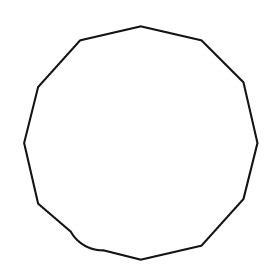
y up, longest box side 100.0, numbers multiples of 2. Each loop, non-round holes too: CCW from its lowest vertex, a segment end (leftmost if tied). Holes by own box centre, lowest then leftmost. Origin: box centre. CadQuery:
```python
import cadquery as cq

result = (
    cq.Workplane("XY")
    .moveTo(0.0, -50.0)
    .lineTo(26.0, -44.0)
    .lineTo(44.0, -24.0)
    .lineTo(50.0, 0.0)
    .lineTo(44.0, 26.0)
    .lineTo(26.0, 44.0)
    .lineTo(0.0, 50.0)
    .lineTo(-26.0, 44.0)
    .lineTo(-44.0, 24.0)
    .lineTo(-50.0, 0.0)
    .lineTo(-44.0, -26.0)
    .lineTo(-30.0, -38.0)
    .threePointArc((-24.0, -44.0), (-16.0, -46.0))
    .close()
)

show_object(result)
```